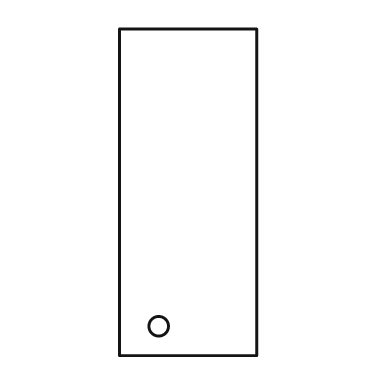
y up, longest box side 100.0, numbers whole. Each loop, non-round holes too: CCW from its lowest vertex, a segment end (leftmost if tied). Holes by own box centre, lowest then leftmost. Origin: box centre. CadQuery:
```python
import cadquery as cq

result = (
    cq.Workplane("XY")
    .moveTo(-21.0, -50.0)
    .lineTo(21.0, -50.0)
    .lineTo(21.0, 50.0)
    .lineTo(-21.0, 50.0)
    .close()
    .moveTo(-9.0, -41.0)
    .circle(3.0)
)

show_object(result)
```